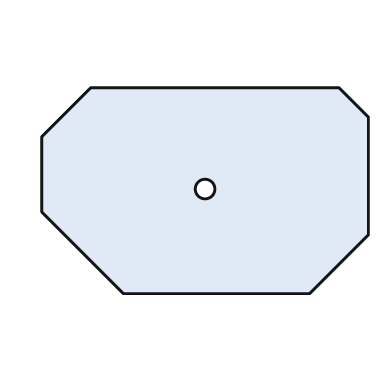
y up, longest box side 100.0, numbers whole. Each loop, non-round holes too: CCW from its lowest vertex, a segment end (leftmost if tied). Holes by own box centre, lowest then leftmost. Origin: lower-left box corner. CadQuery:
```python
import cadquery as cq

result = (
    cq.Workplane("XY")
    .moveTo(25.0, 0.0)
    .lineTo(82.0, 0.0)
    .lineTo(100.0, 18.0)
    .lineTo(100.0, 54.0)
    .lineTo(91.0, 63.0)
    .lineTo(15.0, 63.0)
    .lineTo(0.0, 48.0)
    .lineTo(0.0, 25.0)
    .close()
    .moveTo(50.0, 32.0)
    .circle(3.0)
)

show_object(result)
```